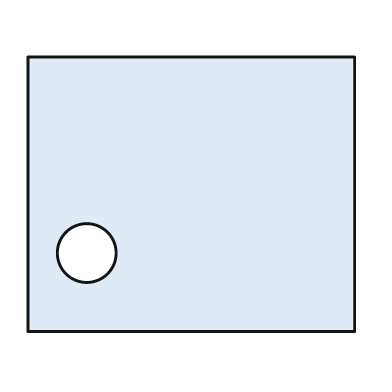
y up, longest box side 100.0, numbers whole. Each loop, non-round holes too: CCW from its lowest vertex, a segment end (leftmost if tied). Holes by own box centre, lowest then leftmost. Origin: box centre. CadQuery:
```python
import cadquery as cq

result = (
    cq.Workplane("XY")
    .moveTo(-50.0, -42.0)
    .lineTo(50.0, -42.0)
    .lineTo(50.0, 42.0)
    .lineTo(-50.0, 42.0)
    .close()
    .moveTo(-32.0, -18.0)
    .circle(9.0)
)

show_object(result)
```